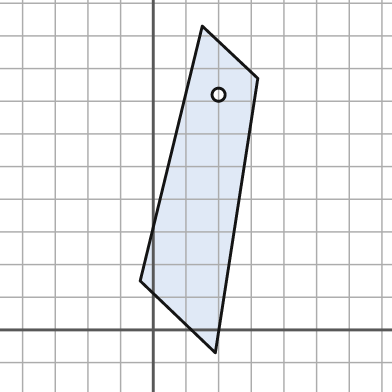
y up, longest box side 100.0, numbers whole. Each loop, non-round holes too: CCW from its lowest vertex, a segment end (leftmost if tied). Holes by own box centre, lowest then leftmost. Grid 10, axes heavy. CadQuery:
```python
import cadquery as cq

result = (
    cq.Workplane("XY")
    .moveTo(19.0, -7.0)
    .lineTo(32.0, 77.0)
    .lineTo(15.0, 93.0)
    .lineTo(-4.0, 15.0)
    .close()
    .moveTo(20.0, 72.0)
    .circle(2.0)
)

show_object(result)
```